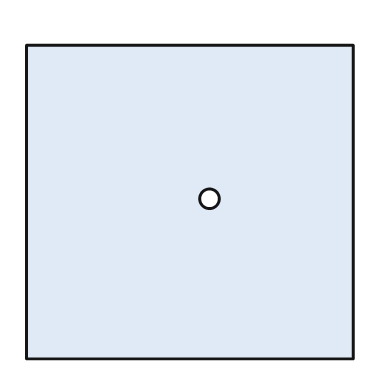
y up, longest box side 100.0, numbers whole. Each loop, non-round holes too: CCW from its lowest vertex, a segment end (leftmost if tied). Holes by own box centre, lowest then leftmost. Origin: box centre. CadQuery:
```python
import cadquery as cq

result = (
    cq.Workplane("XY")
    .moveTo(-50.0, -48.0)
    .lineTo(50.0, -48.0)
    .lineTo(50.0, 48.0)
    .lineTo(-50.0, 48.0)
    .close()
    .moveTo(6.0, 1.0)
    .circle(3.0)
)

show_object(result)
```